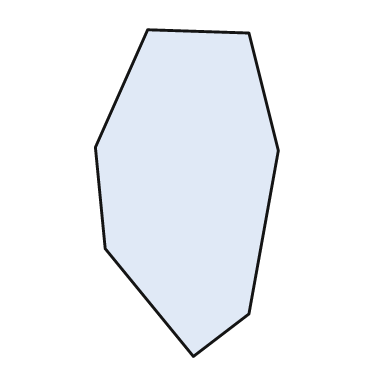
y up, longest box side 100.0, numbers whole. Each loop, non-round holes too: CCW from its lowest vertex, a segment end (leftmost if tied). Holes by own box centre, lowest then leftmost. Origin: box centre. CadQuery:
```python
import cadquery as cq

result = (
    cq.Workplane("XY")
    .moveTo(2.0, -50.0)
    .lineTo(19.0, -37.0)
    .lineTo(28.0, 13.0)
    .lineTo(19.0, 49.0)
    .lineTo(-12.0, 50.0)
    .lineTo(-28.0, 14.0)
    .lineTo(-25.0, -17.0)
    .close()
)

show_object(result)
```